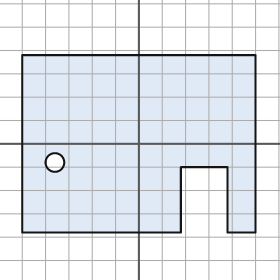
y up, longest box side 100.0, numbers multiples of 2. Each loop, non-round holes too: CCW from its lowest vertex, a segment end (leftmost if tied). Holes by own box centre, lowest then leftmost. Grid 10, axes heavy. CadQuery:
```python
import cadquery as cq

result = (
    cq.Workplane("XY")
    .moveTo(-50.0, -38.0)
    .lineTo(18.0, -38.0)
    .lineTo(18.0, -10.0)
    .lineTo(38.0, -10.0)
    .lineTo(38.0, -38.0)
    .lineTo(50.0, -38.0)
    .lineTo(50.0, 38.0)
    .lineTo(-50.0, 38.0)
    .close()
    .moveTo(-36.0, -8.0)
    .circle(4.0)
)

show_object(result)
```